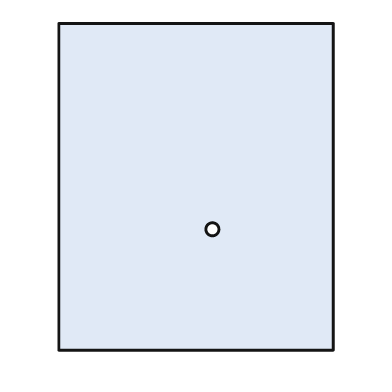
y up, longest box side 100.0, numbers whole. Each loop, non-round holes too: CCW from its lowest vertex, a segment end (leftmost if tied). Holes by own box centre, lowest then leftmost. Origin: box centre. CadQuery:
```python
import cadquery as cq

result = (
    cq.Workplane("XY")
    .moveTo(-42.0, -50.0)
    .lineTo(42.0, -50.0)
    .lineTo(42.0, 50.0)
    .lineTo(-42.0, 50.0)
    .close()
    .moveTo(5.0, -13.0)
    .circle(2.0)
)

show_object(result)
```